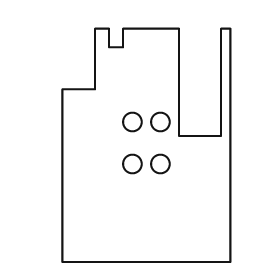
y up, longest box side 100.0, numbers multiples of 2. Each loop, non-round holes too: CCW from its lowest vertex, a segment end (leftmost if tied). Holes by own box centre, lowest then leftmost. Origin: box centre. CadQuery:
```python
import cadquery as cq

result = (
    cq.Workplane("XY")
    .moveTo(-36.0, -50.0)
    .lineTo(36.0, -50.0)
    .lineTo(36.0, 50.0)
    .lineTo(32.0, 50.0)
    .lineTo(32.0, 4.0)
    .lineTo(14.0, 4.0)
    .lineTo(14.0, 50.0)
    .lineTo(-10.0, 50.0)
    .lineTo(-10.0, 42.0)
    .lineTo(-16.0, 42.0)
    .lineTo(-16.0, 50.0)
    .lineTo(-22.0, 50.0)
    .lineTo(-22.0, 24.0)
    .lineTo(-36.0, 24.0)
    .close()
    .moveTo(-6.0, -8.0)
    .circle(4.0)
    .moveTo(6.0, -8.0)
    .circle(4.0)
    .moveTo(-6.0, 10.0)
    .circle(4.0)
    .moveTo(6.0, 10.0)
    .circle(4.0)
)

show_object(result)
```